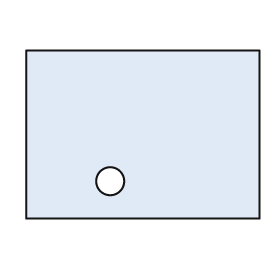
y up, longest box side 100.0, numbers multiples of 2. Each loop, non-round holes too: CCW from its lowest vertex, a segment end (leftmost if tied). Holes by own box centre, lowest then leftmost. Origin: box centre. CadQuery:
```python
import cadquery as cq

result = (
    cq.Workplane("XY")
    .moveTo(-50.0, -36.0)
    .lineTo(50.0, -36.0)
    .lineTo(50.0, 36.0)
    .lineTo(-50.0, 36.0)
    .close()
    .moveTo(-14.0, -20.0)
    .circle(6.0)
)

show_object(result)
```